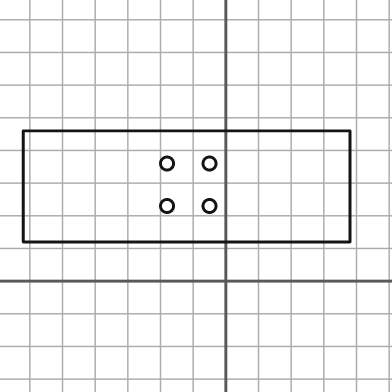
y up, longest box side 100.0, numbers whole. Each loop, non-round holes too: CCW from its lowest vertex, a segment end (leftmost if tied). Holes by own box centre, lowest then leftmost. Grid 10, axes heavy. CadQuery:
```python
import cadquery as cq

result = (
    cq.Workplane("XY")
    .moveTo(-62.0, 12.0)
    .lineTo(38.0, 12.0)
    .lineTo(38.0, 46.0)
    .lineTo(-62.0, 46.0)
    .close()
    .moveTo(-18.0, 23.0)
    .circle(2.0)
    .moveTo(-5.0, 23.0)
    .circle(2.0)
    .moveTo(-18.0, 36.0)
    .circle(2.0)
    .moveTo(-5.0, 36.0)
    .circle(2.0)
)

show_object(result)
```